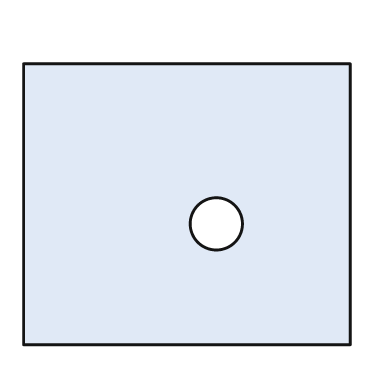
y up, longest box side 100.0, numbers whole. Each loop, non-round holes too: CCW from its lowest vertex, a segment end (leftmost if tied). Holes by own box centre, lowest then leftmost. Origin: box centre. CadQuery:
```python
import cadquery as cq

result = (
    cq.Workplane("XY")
    .moveTo(-50.0, -43.0)
    .lineTo(50.0, -43.0)
    .lineTo(50.0, 43.0)
    .lineTo(-50.0, 43.0)
    .close()
    .moveTo(9.0, -6.0)
    .circle(8.0)
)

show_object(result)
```